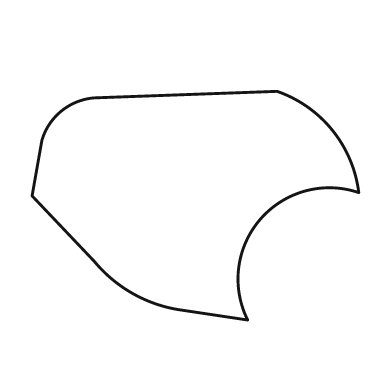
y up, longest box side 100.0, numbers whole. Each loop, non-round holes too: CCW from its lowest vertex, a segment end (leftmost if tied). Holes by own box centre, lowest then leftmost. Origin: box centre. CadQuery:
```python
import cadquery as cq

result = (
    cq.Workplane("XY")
    .moveTo(16.0, -35.0)
    .threePointArc((20.0, -4.0), (50.0, 4.0))
    .threePointArc((42.0, 23.0), (25.0, 35.0))
    .lineTo(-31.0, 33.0)
    .threePointArc((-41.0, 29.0), (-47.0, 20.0))
    .lineTo(-50.0, 3.0)
    .lineTo(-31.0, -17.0)
    .threePointArc((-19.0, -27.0), (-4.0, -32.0))
    .close()
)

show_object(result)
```